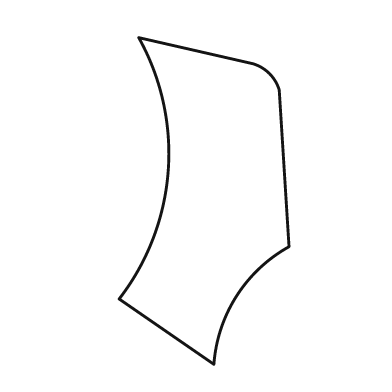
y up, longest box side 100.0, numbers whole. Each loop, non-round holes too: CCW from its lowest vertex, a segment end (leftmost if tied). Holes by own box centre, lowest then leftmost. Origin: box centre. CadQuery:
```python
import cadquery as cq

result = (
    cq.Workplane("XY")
    .moveTo(3.0, -50.0)
    .threePointArc((10.0, -29.0), (26.0, -14.0))
    .lineTo(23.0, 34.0)
    .threePointArc((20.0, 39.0), (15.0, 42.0))
    .lineTo(-20.0, 50.0)
    .threePointArc((-11.0, 9.0), (-26.0, -30.0))
    .close()
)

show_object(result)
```